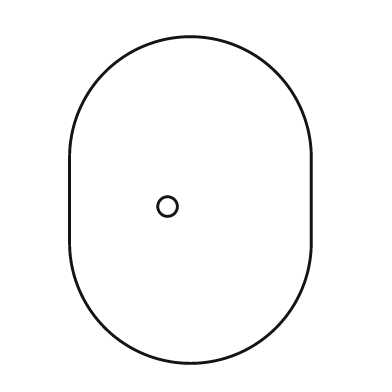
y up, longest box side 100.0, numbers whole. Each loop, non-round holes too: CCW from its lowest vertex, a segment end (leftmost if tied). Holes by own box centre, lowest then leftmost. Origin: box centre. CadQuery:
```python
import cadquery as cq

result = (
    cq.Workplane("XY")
    .moveTo(-37.0, -13.0)
    .threePointArc((0.0, -50.0), (37.0, -13.0))
    .lineTo(37.0, 13.0)
    .threePointArc((0.0, 50.0), (-37.0, 13.0))
    .close()
    .moveTo(-7.0, -2.0)
    .circle(3.0)
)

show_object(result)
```